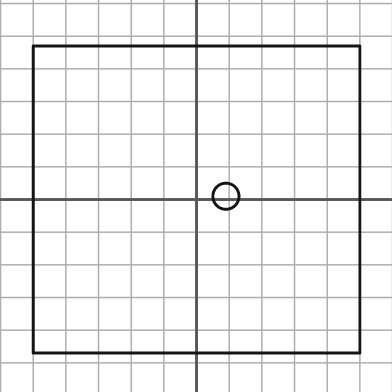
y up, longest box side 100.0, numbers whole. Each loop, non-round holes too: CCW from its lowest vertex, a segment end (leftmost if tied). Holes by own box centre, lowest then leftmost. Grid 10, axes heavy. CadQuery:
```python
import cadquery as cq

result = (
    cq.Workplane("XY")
    .moveTo(-50.0, -47.0)
    .lineTo(50.0, -47.0)
    .lineTo(50.0, 47.0)
    .lineTo(-50.0, 47.0)
    .close()
    .moveTo(9.0, 1.0)
    .circle(4.0)
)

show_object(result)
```